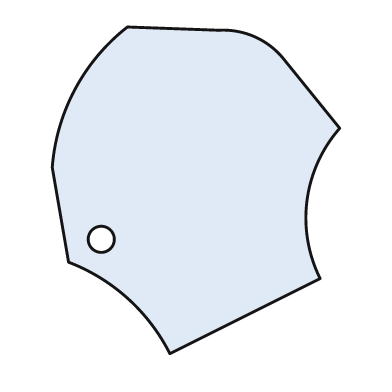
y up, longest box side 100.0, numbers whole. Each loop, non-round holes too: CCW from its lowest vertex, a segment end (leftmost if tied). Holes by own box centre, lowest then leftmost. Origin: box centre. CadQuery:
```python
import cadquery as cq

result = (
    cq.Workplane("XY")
    .moveTo(-8.0, -50.0)
    .lineTo(38.0, -27.0)
    .threePointArc((34.0, -3.0), (44.0, 19.0))
    .lineTo(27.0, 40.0)
    .threePointArc((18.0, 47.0), (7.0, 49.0))
    .lineTo(-21.0, 50.0)
    .threePointArc((-37.0, 31.0), (-44.0, 7.0))
    .lineTo(-39.0, -22.0)
    .threePointArc((-21.0, -33.0), (-8.0, -50.0))
    .close()
    .moveTo(-29.0, -15.0)
    .circle(4.0)
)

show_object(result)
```